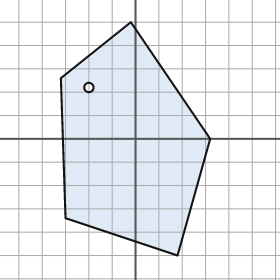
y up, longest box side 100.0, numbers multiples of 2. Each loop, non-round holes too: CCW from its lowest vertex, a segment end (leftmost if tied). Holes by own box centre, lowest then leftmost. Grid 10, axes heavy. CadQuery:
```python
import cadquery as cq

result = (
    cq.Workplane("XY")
    .moveTo(18.0, -50.0)
    .lineTo(32.0, 0.0)
    .lineTo(-2.0, 50.0)
    .lineTo(-32.0, 26.0)
    .lineTo(-30.0, -34.0)
    .close()
    .moveTo(-20.0, 22.0)
    .circle(2.0)
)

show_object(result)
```